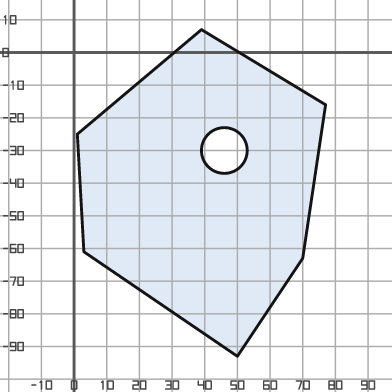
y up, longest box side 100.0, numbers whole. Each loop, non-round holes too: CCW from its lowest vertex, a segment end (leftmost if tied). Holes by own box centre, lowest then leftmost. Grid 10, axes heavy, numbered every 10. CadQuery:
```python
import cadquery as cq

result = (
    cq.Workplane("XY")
    .moveTo(50.0, -93.0)
    .lineTo(70.0, -63.0)
    .lineTo(77.0, -16.0)
    .lineTo(39.0, 7.0)
    .lineTo(1.0, -25.0)
    .lineTo(3.0, -61.0)
    .close()
    .moveTo(46.0, -30.0)
    .circle(7.0)
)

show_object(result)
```